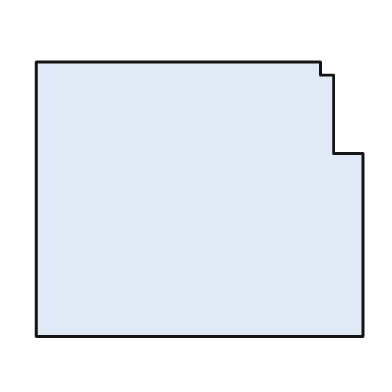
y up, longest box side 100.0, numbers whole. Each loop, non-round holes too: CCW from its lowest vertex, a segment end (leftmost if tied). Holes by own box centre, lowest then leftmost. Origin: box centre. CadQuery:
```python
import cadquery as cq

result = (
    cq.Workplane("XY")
    .moveTo(-50.0, -42.0)
    .lineTo(50.0, -42.0)
    .lineTo(50.0, 14.0)
    .lineTo(41.0, 14.0)
    .lineTo(41.0, 38.0)
    .lineTo(37.0, 38.0)
    .lineTo(37.0, 42.0)
    .lineTo(-50.0, 42.0)
    .close()
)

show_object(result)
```